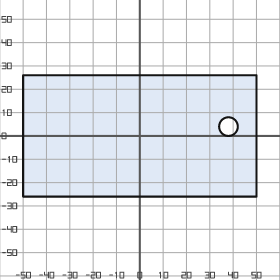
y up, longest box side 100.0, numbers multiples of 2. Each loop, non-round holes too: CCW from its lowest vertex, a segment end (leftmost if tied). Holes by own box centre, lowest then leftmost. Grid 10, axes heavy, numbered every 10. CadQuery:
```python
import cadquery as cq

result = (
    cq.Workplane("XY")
    .moveTo(-50.0, -26.0)
    .lineTo(50.0, -26.0)
    .lineTo(50.0, 26.0)
    .lineTo(-50.0, 26.0)
    .close()
    .moveTo(38.0, 4.0)
    .circle(4.0)
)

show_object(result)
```